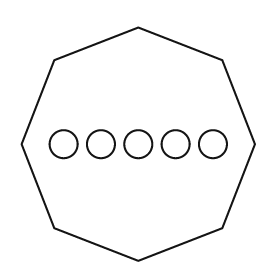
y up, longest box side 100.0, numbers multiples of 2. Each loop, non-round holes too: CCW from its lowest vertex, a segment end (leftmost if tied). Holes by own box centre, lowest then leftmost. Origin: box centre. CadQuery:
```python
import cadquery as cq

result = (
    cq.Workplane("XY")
    .moveTo(0.0, -50.0)
    .lineTo(36.0, -36.0)
    .lineTo(50.0, 0.0)
    .lineTo(36.0, 36.0)
    .lineTo(0.0, 50.0)
    .lineTo(-36.0, 36.0)
    .lineTo(-50.0, 0.0)
    .lineTo(-36.0, -36.0)
    .close()
    .moveTo(-32.0, 0.0)
    .circle(6.0)
    .moveTo(-16.0, 0.0)
    .circle(6.0)
    .moveTo(0.0, 0.0)
    .circle(6.0)
    .moveTo(16.0, 0.0)
    .circle(6.0)
    .moveTo(32.0, 0.0)
    .circle(6.0)
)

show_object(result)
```